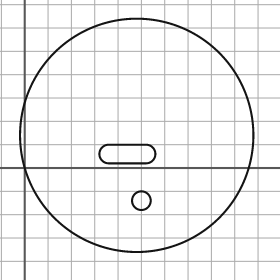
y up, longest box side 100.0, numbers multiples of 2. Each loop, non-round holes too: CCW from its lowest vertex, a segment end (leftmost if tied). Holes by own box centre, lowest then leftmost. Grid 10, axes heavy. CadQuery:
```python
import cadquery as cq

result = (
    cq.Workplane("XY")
    .moveTo(48.0, 14.0)
    .circle(50.0)
    .moveTo(50.0, -14.0)
    .circle(4.0)
    .moveTo(36.0, 2.0)
    .lineTo(52.0, 2.0)
    .threePointArc((56.0, 6.0), (52.0, 10.0))
    .lineTo(36.0, 10.0)
    .threePointArc((32.0, 6.0), (36.0, 2.0))
    .close()
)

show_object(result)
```